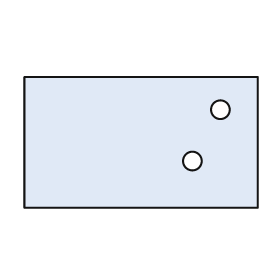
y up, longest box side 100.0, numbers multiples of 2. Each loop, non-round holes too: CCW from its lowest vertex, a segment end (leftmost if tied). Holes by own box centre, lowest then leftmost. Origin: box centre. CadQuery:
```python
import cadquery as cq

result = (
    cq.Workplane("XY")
    .moveTo(-50.0, -28.0)
    .lineTo(50.0, -28.0)
    .lineTo(50.0, 28.0)
    .lineTo(-50.0, 28.0)
    .close()
    .moveTo(22.0, -8.0)
    .circle(4.0)
    .moveTo(34.0, 14.0)
    .circle(4.0)
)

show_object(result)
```